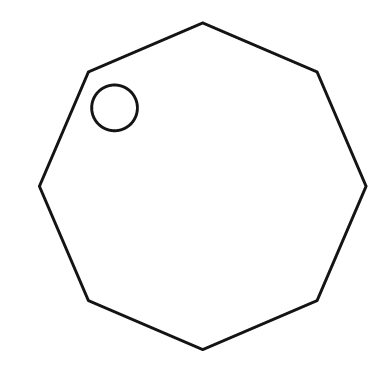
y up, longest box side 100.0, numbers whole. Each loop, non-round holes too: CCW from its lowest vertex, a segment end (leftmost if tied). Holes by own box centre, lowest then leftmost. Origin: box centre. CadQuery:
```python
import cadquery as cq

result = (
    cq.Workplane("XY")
    .moveTo(0.0, -50.0)
    .lineTo(35.0, -35.0)
    .lineTo(50.0, 0.0)
    .lineTo(35.0, 35.0)
    .lineTo(0.0, 50.0)
    .lineTo(-35.0, 35.0)
    .lineTo(-50.0, 0.0)
    .lineTo(-35.0, -35.0)
    .close()
    .moveTo(-27.0, 24.0)
    .circle(7.0)
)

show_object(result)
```